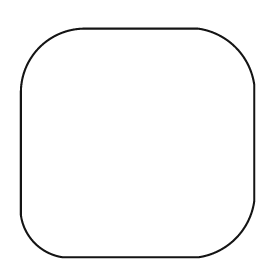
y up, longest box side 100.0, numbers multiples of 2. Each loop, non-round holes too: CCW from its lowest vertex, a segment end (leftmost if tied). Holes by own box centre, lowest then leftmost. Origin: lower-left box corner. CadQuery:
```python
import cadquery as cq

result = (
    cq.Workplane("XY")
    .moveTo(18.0, 0.0)
    .lineTo(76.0, 0.0)
    .threePointArc((92.0, 8.0), (100.0, 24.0))
    .lineTo(100.0, 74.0)
    .threePointArc((92.0, 90.0), (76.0, 98.0))
    .lineTo(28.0, 98.0)
    .threePointArc((8.0, 90.0), (0.0, 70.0))
    .lineTo(0.0, 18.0)
    .threePointArc((6.0, 6.0), (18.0, 0.0))
    .close()
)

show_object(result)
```